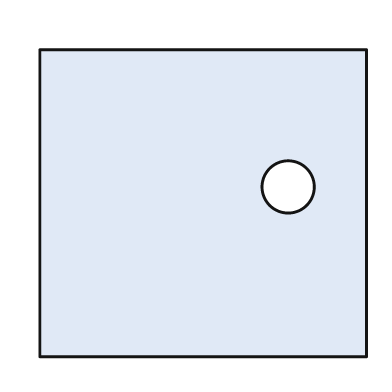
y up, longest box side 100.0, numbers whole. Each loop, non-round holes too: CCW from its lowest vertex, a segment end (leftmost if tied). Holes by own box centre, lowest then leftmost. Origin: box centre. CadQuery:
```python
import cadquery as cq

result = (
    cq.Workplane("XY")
    .moveTo(-50.0, -47.0)
    .lineTo(50.0, -47.0)
    .lineTo(50.0, 47.0)
    .lineTo(-50.0, 47.0)
    .close()
    .moveTo(26.0, 5.0)
    .circle(8.0)
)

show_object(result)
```